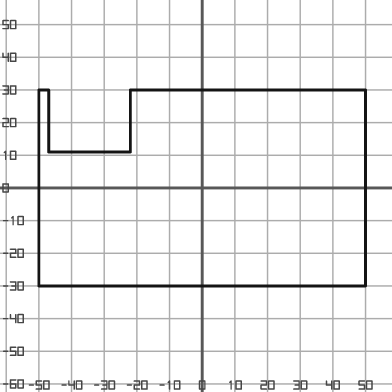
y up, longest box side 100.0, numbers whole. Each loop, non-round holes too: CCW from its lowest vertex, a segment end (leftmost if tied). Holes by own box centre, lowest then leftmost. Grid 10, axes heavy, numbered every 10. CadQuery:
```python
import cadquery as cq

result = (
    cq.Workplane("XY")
    .moveTo(-50.0, -30.0)
    .lineTo(50.0, -30.0)
    .lineTo(50.0, 30.0)
    .lineTo(-22.0, 30.0)
    .lineTo(-22.0, 11.0)
    .lineTo(-47.0, 11.0)
    .lineTo(-47.0, 30.0)
    .lineTo(-50.0, 30.0)
    .close()
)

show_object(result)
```